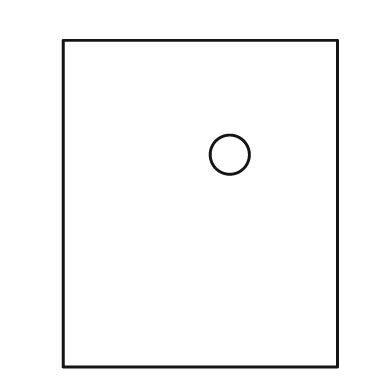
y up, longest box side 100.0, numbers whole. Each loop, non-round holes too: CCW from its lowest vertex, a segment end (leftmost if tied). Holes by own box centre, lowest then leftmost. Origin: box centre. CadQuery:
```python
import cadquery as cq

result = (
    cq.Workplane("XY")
    .moveTo(-42.0, -50.0)
    .lineTo(42.0, -50.0)
    .lineTo(42.0, 50.0)
    .lineTo(-42.0, 50.0)
    .close()
    .moveTo(9.0, 15.0)
    .circle(6.0)
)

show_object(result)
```